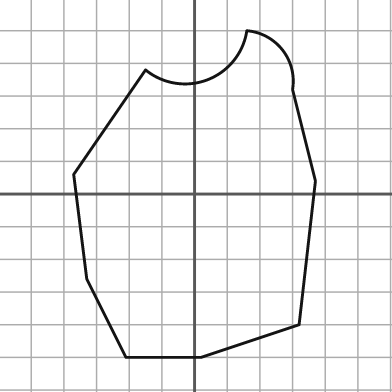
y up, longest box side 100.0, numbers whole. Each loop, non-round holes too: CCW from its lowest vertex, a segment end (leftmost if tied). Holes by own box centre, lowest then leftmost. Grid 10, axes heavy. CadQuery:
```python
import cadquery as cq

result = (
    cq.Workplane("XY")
    .moveTo(-21.0, -50.0)
    .lineTo(2.0, -50.0)
    .lineTo(32.0, -40.0)
    .lineTo(37.0, 4.0)
    .lineTo(30.0, 32.0)
    .threePointArc((27.0, 44.0), (16.0, 50.0))
    .threePointArc((4.0, 35.0), (-15.0, 38.0))
    .lineTo(-37.0, 6.0)
    .lineTo(-33.0, -26.0)
    .close()
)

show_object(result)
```